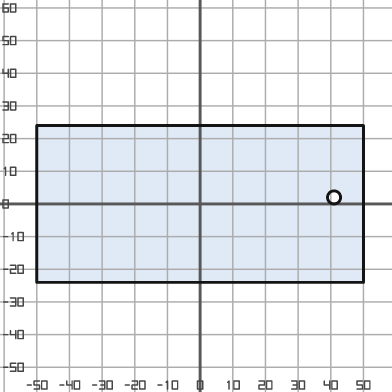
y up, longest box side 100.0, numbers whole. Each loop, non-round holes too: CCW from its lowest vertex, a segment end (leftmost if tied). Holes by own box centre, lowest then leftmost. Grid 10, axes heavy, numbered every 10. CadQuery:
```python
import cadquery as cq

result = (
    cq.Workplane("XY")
    .moveTo(-50.0, -24.0)
    .lineTo(50.0, -24.0)
    .lineTo(50.0, 24.0)
    .lineTo(-50.0, 24.0)
    .close()
    .moveTo(41.0, 2.0)
    .circle(2.0)
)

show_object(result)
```